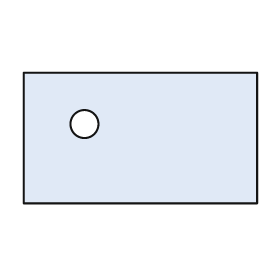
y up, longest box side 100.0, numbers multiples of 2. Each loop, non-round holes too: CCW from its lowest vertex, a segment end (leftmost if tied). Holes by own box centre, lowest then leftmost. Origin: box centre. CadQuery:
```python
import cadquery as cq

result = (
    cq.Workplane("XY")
    .moveTo(-50.0, -28.0)
    .lineTo(50.0, -28.0)
    .lineTo(50.0, 28.0)
    .lineTo(-50.0, 28.0)
    .close()
    .moveTo(-24.0, 6.0)
    .circle(6.0)
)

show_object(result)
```